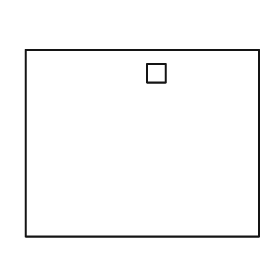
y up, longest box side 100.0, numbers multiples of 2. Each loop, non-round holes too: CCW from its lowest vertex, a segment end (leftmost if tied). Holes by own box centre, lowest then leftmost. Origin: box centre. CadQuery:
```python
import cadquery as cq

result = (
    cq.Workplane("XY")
    .moveTo(-50.0, -40.0)
    .lineTo(50.0, -40.0)
    .lineTo(50.0, 40.0)
    .lineTo(-50.0, 40.0)
    .close()
    .moveTo(2.0, 26.0)
    .lineTo(10.0, 26.0)
    .lineTo(10.0, 34.0)
    .lineTo(2.0, 34.0)
    .close()
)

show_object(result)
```